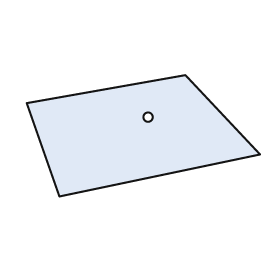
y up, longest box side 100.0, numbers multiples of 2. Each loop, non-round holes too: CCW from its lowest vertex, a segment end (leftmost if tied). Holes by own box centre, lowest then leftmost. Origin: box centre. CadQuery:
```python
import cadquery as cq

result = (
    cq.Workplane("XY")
    .moveTo(-36.0, -26.0)
    .lineTo(50.0, -8.0)
    .lineTo(18.0, 26.0)
    .lineTo(-50.0, 14.0)
    .close()
    .moveTo(2.0, 8.0)
    .circle(2.0)
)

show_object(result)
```